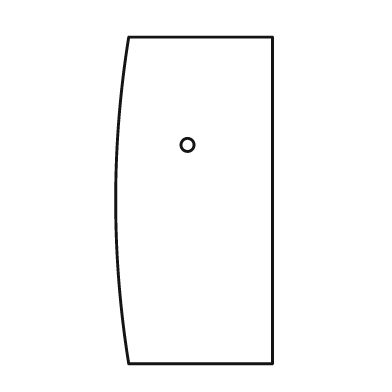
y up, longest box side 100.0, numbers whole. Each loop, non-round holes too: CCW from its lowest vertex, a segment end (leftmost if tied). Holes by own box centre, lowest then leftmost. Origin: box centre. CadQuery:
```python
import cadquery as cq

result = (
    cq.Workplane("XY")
    .moveTo(-20.0, -50.0)
    .lineTo(24.0, -50.0)
    .lineTo(24.0, 50.0)
    .lineTo(-20.0, 50.0)
    .threePointArc((-24.0, 0.0), (-20.0, -50.0))
    .close()
    .moveTo(-2.0, 17.0)
    .circle(2.0)
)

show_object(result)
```